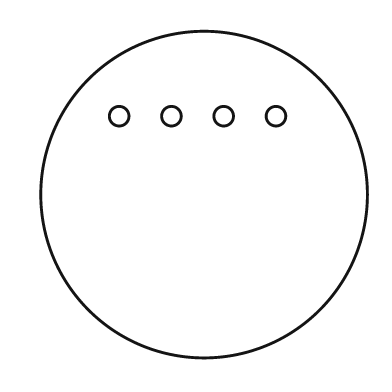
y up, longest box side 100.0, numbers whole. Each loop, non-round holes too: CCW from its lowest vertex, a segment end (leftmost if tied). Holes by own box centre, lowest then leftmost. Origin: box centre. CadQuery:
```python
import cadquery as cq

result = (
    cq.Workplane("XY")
    .moveTo(0.0, 0.0)
    .circle(50.0)
    .moveTo(-26.0, 24.0)
    .circle(3.0)
    .moveTo(-10.0, 24.0)
    .circle(3.0)
    .moveTo(6.0, 24.0)
    .circle(3.0)
    .moveTo(22.0, 24.0)
    .circle(3.0)
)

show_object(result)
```